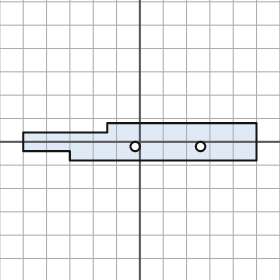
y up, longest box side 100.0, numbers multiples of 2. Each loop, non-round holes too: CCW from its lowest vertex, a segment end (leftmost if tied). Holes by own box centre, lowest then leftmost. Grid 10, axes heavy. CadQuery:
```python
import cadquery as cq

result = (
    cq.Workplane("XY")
    .moveTo(-30.0, -8.0)
    .lineTo(50.0, -8.0)
    .lineTo(50.0, 8.0)
    .lineTo(-14.0, 8.0)
    .lineTo(-14.0, 4.0)
    .lineTo(-50.0, 4.0)
    .lineTo(-50.0, -4.0)
    .lineTo(-30.0, -4.0)
    .close()
    .moveTo(-2.0, -2.0)
    .circle(2.0)
    .moveTo(26.0, -2.0)
    .circle(2.0)
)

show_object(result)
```